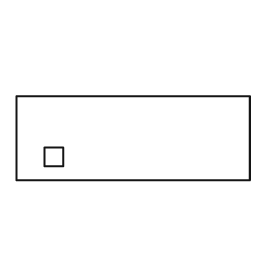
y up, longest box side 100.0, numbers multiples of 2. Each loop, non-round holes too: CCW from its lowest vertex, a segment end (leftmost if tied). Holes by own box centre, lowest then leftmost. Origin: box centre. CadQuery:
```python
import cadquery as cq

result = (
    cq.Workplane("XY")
    .moveTo(-50.0, -18.0)
    .lineTo(50.0, -18.0)
    .lineTo(50.0, 18.0)
    .lineTo(-50.0, 18.0)
    .close()
    .moveTo(-38.0, -12.0)
    .lineTo(-30.0, -12.0)
    .lineTo(-30.0, -4.0)
    .lineTo(-38.0, -4.0)
    .close()
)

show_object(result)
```